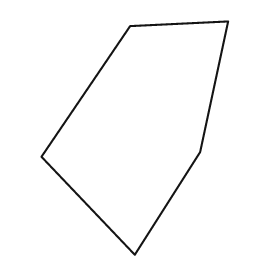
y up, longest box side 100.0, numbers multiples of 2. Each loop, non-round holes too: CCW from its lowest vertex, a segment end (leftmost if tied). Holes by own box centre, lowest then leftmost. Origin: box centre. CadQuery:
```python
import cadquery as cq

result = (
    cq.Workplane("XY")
    .moveTo(0.0, -50.0)
    .lineTo(28.0, -6.0)
    .lineTo(40.0, 50.0)
    .lineTo(-2.0, 48.0)
    .lineTo(-40.0, -8.0)
    .close()
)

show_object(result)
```